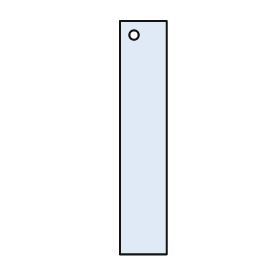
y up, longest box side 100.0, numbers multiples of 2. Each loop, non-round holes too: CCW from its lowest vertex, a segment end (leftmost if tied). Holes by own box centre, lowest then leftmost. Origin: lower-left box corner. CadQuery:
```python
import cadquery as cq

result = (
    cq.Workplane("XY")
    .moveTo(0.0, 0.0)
    .lineTo(20.0, 0.0)
    .lineTo(20.0, 100.0)
    .lineTo(0.0, 100.0)
    .close()
    .moveTo(6.0, 94.0)
    .circle(2.0)
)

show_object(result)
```